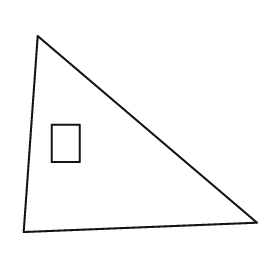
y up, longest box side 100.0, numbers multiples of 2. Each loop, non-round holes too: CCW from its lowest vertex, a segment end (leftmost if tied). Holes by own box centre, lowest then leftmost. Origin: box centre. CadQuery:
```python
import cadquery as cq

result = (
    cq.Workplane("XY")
    .moveTo(-50.0, -42.0)
    .lineTo(50.0, -38.0)
    .lineTo(-44.0, 42.0)
    .close()
    .moveTo(-38.0, -12.0)
    .lineTo(-26.0, -12.0)
    .lineTo(-26.0, 4.0)
    .lineTo(-38.0, 4.0)
    .close()
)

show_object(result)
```